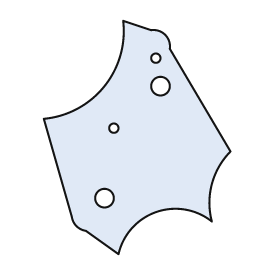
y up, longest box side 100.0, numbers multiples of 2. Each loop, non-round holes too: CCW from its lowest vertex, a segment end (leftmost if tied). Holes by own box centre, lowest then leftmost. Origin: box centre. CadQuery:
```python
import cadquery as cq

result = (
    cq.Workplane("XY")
    .moveTo(-8.0, -50.0)
    .threePointArc((8.0, -32.0), (32.0, -36.0))
    .threePointArc((32.0, -20.0), (40.0, -6.0))
    .lineTo(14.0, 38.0)
    .threePointArc((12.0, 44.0), (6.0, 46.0))
    .lineTo(-6.0, 50.0)
    .threePointArc((-14.0, 22.0), (-40.0, 8.0))
    .lineTo(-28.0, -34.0)
    .threePointArc((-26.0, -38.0), (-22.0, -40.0))
    .close()
    .moveTo(-14.0, -26.0)
    .circle(4.0)
    .moveTo(-10.0, 4.0)
    .circle(2.0)
    .moveTo(10.0, 22.0)
    .circle(4.0)
    .moveTo(8.0, 34.0)
    .circle(2.0)
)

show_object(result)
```